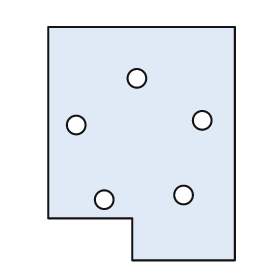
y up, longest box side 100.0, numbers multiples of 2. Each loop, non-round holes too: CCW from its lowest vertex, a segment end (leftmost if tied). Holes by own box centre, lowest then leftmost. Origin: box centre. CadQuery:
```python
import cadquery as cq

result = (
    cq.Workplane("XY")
    .moveTo(-4.0, -50.0)
    .lineTo(40.0, -50.0)
    .lineTo(40.0, 50.0)
    .lineTo(-40.0, 50.0)
    .lineTo(-40.0, -32.0)
    .lineTo(-4.0, -32.0)
    .close()
    .moveTo(-16.0, -24.0)
    .circle(4.0)
    .moveTo(18.0, -22.0)
    .circle(4.0)
    .moveTo(-28.0, 8.0)
    .circle(4.0)
    .moveTo(26.0, 10.0)
    .circle(4.0)
    .moveTo(-2.0, 28.0)
    .circle(4.0)
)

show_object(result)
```